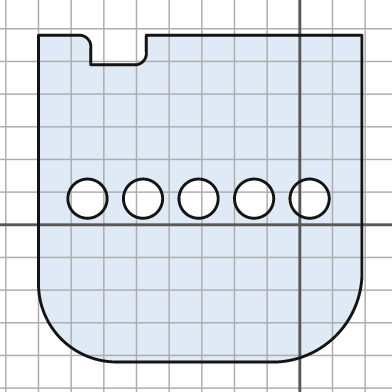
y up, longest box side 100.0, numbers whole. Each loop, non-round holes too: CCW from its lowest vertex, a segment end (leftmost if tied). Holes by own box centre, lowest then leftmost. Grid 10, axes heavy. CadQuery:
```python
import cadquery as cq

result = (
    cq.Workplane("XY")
    .moveTo(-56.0, -42.0)
    .lineTo(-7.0, -42.0)
    .threePointArc((11.0, -34.0), (19.0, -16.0))
    .lineTo(19.0, 58.0)
    .lineTo(-47.0, 58.0)
    .lineTo(-47.0, 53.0)
    .threePointArc((-48.0, 50.0), (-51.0, 49.0))
    .lineTo(-64.0, 49.0)
    .lineTo(-64.0, 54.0)
    .threePointArc((-65.0, 57.0), (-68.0, 58.0))
    .lineTo(-80.0, 58.0)
    .lineTo(-80.0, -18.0)
    .threePointArc((-73.0, -35.0), (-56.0, -42.0))
    .close()
    .moveTo(-65.0, 8.0)
    .circle(6.0)
    .moveTo(-48.0, 8.0)
    .circle(6.0)
    .moveTo(-31.0, 8.0)
    .circle(6.0)
    .moveTo(-14.0, 8.0)
    .circle(6.0)
    .moveTo(3.0, 8.0)
    .circle(6.0)
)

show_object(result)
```